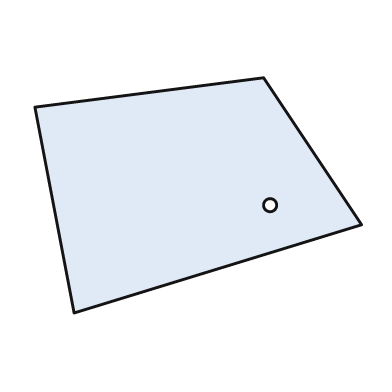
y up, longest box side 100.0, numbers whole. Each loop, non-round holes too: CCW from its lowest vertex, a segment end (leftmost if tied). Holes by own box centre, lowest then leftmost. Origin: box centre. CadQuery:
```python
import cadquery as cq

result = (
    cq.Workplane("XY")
    .moveTo(-38.0, -36.0)
    .lineTo(50.0, -9.0)
    .lineTo(20.0, 36.0)
    .lineTo(-50.0, 27.0)
    .close()
    .moveTo(22.0, -3.0)
    .circle(2.0)
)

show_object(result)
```